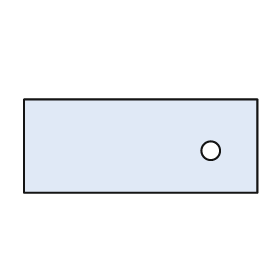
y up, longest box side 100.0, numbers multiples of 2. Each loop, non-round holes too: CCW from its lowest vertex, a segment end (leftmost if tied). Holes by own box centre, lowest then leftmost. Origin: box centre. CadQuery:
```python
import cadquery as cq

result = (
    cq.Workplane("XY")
    .moveTo(-50.0, -20.0)
    .lineTo(50.0, -20.0)
    .lineTo(50.0, 20.0)
    .lineTo(-50.0, 20.0)
    .close()
    .moveTo(30.0, -2.0)
    .circle(4.0)
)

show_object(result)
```